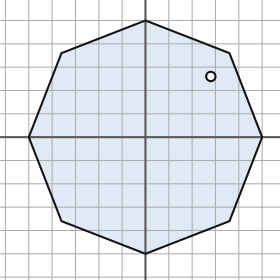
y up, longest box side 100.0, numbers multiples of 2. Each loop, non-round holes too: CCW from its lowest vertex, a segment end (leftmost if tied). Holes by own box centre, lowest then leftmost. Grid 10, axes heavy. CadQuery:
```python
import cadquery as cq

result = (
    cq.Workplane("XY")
    .moveTo(0.0, -50.0)
    .lineTo(36.0, -36.0)
    .lineTo(50.0, 0.0)
    .lineTo(36.0, 36.0)
    .lineTo(0.0, 50.0)
    .lineTo(-36.0, 36.0)
    .lineTo(-50.0, 0.0)
    .lineTo(-36.0, -36.0)
    .close()
    .moveTo(28.0, 26.0)
    .circle(2.0)
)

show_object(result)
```